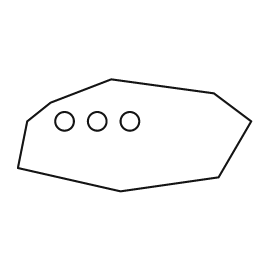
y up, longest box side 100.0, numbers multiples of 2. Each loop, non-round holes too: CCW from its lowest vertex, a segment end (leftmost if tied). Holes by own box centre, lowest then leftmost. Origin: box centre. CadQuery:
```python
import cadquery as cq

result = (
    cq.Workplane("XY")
    .moveTo(-6.0, -24.0)
    .lineTo(36.0, -18.0)
    .lineTo(50.0, 6.0)
    .lineTo(34.0, 18.0)
    .lineTo(-10.0, 24.0)
    .lineTo(-36.0, 14.0)
    .lineTo(-46.0, 6.0)
    .lineTo(-50.0, -14.0)
    .close()
    .moveTo(-30.0, 6.0)
    .circle(4.0)
    .moveTo(-16.0, 6.0)
    .circle(4.0)
    .moveTo(-2.0, 6.0)
    .circle(4.0)
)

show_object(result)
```